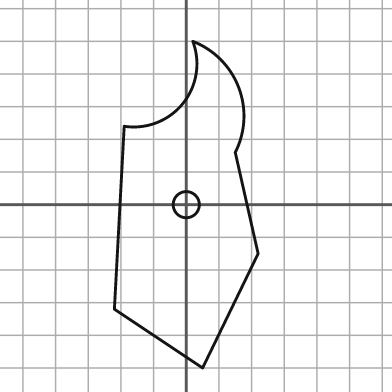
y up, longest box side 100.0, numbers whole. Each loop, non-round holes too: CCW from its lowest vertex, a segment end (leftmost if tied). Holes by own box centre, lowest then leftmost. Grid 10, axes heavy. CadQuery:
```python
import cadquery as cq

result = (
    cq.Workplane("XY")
    .moveTo(5.0, -50.0)
    .lineTo(22.0, -15.0)
    .lineTo(15.0, 16.0)
    .threePointArc((16.0, 36.0), (2.0, 50.0))
    .threePointArc((-1.0, 31.0), (-19.0, 24.0))
    .lineTo(-22.0, -32.0)
    .close()
    .moveTo(0.0, 0.0)
    .circle(4.0)
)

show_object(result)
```